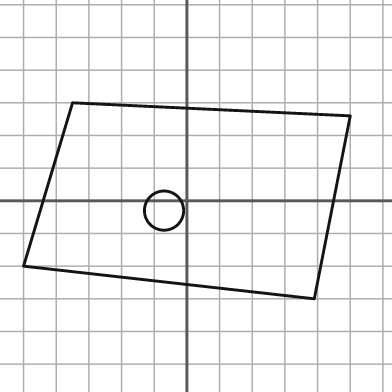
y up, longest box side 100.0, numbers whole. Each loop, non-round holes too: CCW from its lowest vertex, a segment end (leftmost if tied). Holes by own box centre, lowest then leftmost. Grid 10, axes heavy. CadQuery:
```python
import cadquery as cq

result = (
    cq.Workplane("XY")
    .moveTo(39.0, -30.0)
    .lineTo(50.0, 26.0)
    .lineTo(-35.0, 30.0)
    .lineTo(-50.0, -20.0)
    .close()
    .moveTo(-7.0, -3.0)
    .circle(6.0)
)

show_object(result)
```